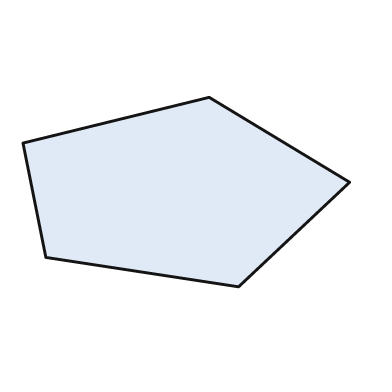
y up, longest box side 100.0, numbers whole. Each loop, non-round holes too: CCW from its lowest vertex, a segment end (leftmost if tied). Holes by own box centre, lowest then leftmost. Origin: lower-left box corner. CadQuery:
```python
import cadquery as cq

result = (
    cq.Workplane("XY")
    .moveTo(66.0, 0.0)
    .lineTo(100.0, 32.0)
    .lineTo(57.0, 58.0)
    .lineTo(0.0, 44.0)
    .lineTo(7.0, 9.0)
    .close()
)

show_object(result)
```